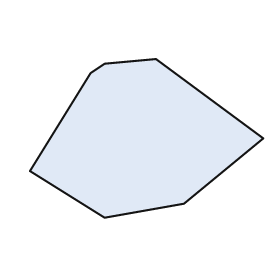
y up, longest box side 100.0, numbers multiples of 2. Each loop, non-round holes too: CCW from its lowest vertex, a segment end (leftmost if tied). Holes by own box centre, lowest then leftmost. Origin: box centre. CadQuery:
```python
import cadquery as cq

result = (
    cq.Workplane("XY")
    .moveTo(-18.0, -34.0)
    .lineTo(16.0, -28.0)
    .lineTo(50.0, 0.0)
    .lineTo(4.0, 34.0)
    .lineTo(-18.0, 32.0)
    .lineTo(-24.0, 28.0)
    .lineTo(-50.0, -14.0)
    .close()
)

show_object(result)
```